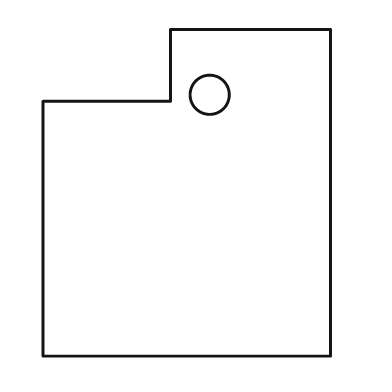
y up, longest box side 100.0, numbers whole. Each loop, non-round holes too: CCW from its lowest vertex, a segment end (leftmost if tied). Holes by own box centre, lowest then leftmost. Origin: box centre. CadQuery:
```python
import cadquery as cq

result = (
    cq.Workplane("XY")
    .moveTo(-44.0, -50.0)
    .lineTo(44.0, -50.0)
    .lineTo(44.0, 50.0)
    .lineTo(-5.0, 50.0)
    .lineTo(-5.0, 28.0)
    .lineTo(-44.0, 28.0)
    .close()
    .moveTo(7.0, 30.0)
    .circle(6.0)
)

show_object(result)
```